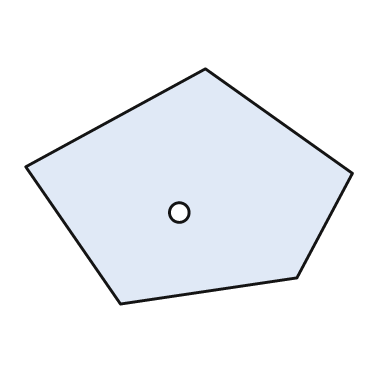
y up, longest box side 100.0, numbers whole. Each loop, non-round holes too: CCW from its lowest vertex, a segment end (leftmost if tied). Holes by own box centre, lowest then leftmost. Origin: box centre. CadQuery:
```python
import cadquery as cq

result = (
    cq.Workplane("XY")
    .moveTo(-21.0, -36.0)
    .lineTo(33.0, -28.0)
    .lineTo(50.0, 4.0)
    .lineTo(5.0, 36.0)
    .lineTo(-50.0, 6.0)
    .close()
    .moveTo(-3.0, -8.0)
    .circle(3.0)
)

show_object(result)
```